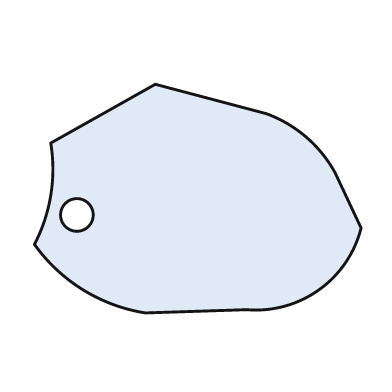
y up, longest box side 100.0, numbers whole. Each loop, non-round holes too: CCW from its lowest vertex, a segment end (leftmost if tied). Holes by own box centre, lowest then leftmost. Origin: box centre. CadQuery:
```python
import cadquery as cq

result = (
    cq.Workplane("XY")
    .moveTo(-16.0, -35.0)
    .lineTo(15.0, -34.0)
    .threePointArc((37.0, -28.0), (50.0, -9.0))
    .lineTo(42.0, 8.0)
    .threePointArc((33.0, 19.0), (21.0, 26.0))
    .lineTo(-13.0, 35.0)
    .lineTo(-45.0, 17.0)
    .threePointArc((-45.0, 1.0), (-50.0, -14.0))
    .threePointArc((-35.0, -28.0), (-16.0, -35.0))
    .close()
    .moveTo(-37.0, -5.0)
    .circle(5.0)
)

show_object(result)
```